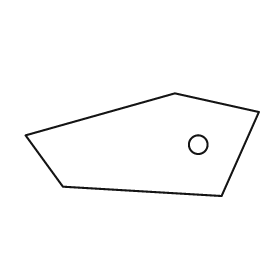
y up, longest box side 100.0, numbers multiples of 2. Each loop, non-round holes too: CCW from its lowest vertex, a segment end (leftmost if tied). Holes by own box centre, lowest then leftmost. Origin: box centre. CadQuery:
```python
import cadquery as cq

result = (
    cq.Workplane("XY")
    .moveTo(34.0, -22.0)
    .lineTo(50.0, 14.0)
    .lineTo(14.0, 22.0)
    .lineTo(-50.0, 4.0)
    .lineTo(-34.0, -18.0)
    .close()
    .moveTo(24.0, 0.0)
    .circle(4.0)
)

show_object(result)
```